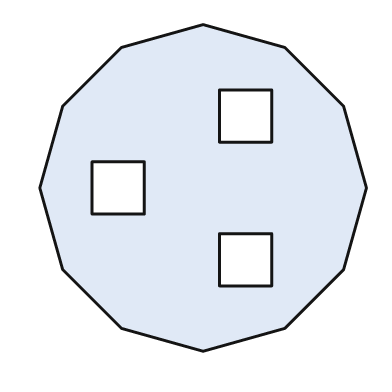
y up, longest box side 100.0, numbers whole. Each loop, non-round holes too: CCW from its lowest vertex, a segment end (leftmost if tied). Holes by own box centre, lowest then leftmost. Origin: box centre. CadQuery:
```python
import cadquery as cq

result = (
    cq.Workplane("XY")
    .moveTo(0.0, -50.0)
    .lineTo(25.0, -43.0)
    .lineTo(43.0, -25.0)
    .lineTo(50.0, 0.0)
    .lineTo(43.0, 25.0)
    .lineTo(25.0, 43.0)
    .lineTo(0.0, 50.0)
    .lineTo(-25.0, 43.0)
    .lineTo(-43.0, 25.0)
    .lineTo(-50.0, 0.0)
    .lineTo(-43.0, -25.0)
    .lineTo(-25.0, -43.0)
    .close()
    .moveTo(5.0, -30.0)
    .lineTo(21.0, -30.0)
    .lineTo(21.0, -14.0)
    .lineTo(5.0, -14.0)
    .close()
    .moveTo(-34.0, -8.0)
    .lineTo(-18.0, -8.0)
    .lineTo(-18.0, 8.0)
    .lineTo(-34.0, 8.0)
    .close()
    .moveTo(5.0, 14.0)
    .lineTo(21.0, 14.0)
    .lineTo(21.0, 30.0)
    .lineTo(5.0, 30.0)
    .close()
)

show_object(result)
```